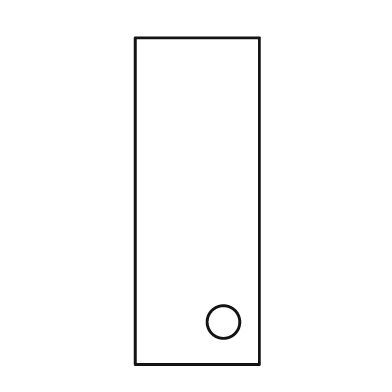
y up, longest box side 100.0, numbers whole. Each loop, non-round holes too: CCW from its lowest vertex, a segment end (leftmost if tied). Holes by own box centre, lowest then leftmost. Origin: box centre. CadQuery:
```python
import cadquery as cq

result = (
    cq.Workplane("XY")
    .moveTo(-19.0, -50.0)
    .lineTo(19.0, -50.0)
    .lineTo(19.0, 50.0)
    .lineTo(-19.0, 50.0)
    .close()
    .moveTo(8.0, -37.0)
    .circle(5.0)
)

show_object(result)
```